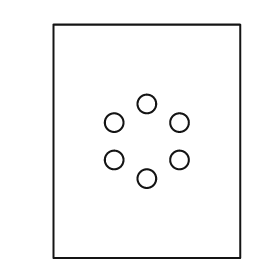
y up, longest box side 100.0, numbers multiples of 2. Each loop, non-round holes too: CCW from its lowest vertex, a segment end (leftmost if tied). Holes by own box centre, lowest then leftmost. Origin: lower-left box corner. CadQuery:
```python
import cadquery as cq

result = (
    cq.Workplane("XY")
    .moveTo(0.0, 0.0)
    .lineTo(80.0, 0.0)
    .lineTo(80.0, 100.0)
    .lineTo(0.0, 100.0)
    .close()
    .moveTo(40.0, 34.0)
    .circle(4.0)
    .moveTo(26.0, 42.0)
    .circle(4.0)
    .moveTo(54.0, 42.0)
    .circle(4.0)
    .moveTo(26.0, 58.0)
    .circle(4.0)
    .moveTo(54.0, 58.0)
    .circle(4.0)
    .moveTo(40.0, 66.0)
    .circle(4.0)
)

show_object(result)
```